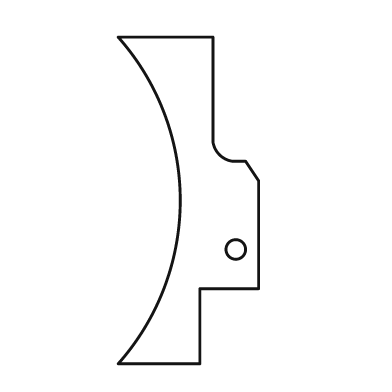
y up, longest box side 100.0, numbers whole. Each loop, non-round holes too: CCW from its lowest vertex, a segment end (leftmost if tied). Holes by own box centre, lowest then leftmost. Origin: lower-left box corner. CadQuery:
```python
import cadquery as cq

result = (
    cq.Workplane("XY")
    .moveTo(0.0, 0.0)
    .lineTo(25.0, 0.0)
    .lineTo(25.0, 23.0)
    .lineTo(43.0, 23.0)
    .lineTo(43.0, 56.0)
    .lineTo(39.0, 62.0)
    .lineTo(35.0, 62.0)
    .threePointArc((31.0, 64.0), (29.0, 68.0))
    .lineTo(29.0, 100.0)
    .lineTo(0.0, 100.0)
    .threePointArc((19.0, 50.0), (0.0, 0.0))
    .close()
    .moveTo(36.0, 35.0)
    .circle(3.0)
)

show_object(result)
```